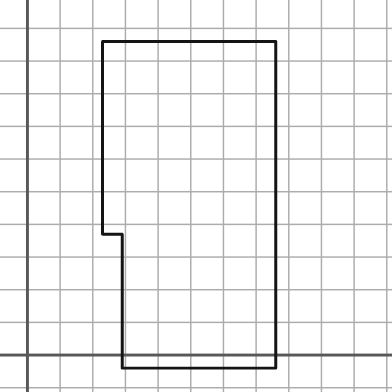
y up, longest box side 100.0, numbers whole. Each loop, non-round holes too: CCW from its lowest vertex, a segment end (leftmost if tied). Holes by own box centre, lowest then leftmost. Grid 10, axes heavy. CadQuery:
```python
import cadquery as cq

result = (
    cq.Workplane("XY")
    .moveTo(29.0, -4.0)
    .lineTo(76.0, -4.0)
    .lineTo(76.0, 96.0)
    .lineTo(23.0, 96.0)
    .lineTo(23.0, 37.0)
    .lineTo(29.0, 37.0)
    .close()
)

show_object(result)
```